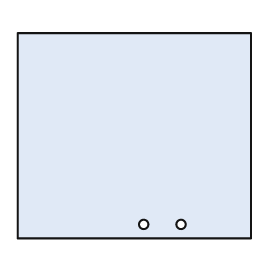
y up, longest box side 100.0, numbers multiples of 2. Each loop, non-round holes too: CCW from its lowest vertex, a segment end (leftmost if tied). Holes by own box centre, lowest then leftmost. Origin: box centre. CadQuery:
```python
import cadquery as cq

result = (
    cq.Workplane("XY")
    .moveTo(-50.0, -44.0)
    .lineTo(50.0, -44.0)
    .lineTo(50.0, 44.0)
    .lineTo(-50.0, 44.0)
    .close()
    .moveTo(4.0, -38.0)
    .circle(2.0)
    .moveTo(20.0, -38.0)
    .circle(2.0)
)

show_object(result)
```